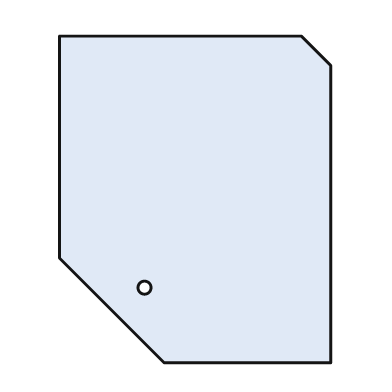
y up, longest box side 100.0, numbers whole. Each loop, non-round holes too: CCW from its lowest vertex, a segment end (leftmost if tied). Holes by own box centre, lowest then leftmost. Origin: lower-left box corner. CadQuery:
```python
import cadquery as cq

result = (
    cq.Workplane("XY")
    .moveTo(32.0, 0.0)
    .lineTo(83.0, 0.0)
    .lineTo(83.0, 91.0)
    .lineTo(74.0, 100.0)
    .lineTo(0.0, 100.0)
    .lineTo(0.0, 32.0)
    .close()
    .moveTo(26.0, 23.0)
    .circle(2.0)
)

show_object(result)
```